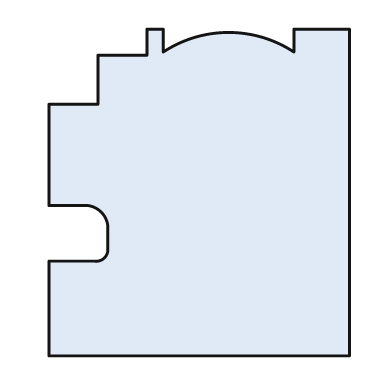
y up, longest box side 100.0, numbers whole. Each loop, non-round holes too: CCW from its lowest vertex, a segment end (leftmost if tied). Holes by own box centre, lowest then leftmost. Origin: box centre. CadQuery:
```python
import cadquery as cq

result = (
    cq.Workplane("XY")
    .moveTo(-46.0, -50.0)
    .lineTo(46.0, -50.0)
    .lineTo(46.0, 50.0)
    .lineTo(29.0, 50.0)
    .lineTo(29.0, 43.0)
    .threePointArc((9.0, 49.0), (-11.0, 43.0))
    .lineTo(-11.0, 50.0)
    .lineTo(-16.0, 50.0)
    .lineTo(-16.0, 42.0)
    .lineTo(-31.0, 42.0)
    .lineTo(-31.0, 27.0)
    .lineTo(-46.0, 27.0)
    .lineTo(-46.0, -4.0)
    .lineTo(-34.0, -4.0)
    .threePointArc((-30.0, -6.0), (-28.0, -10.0))
    .lineTo(-28.0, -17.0)
    .threePointArc((-29.0, -20.0), (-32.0, -21.0))
    .lineTo(-46.0, -21.0)
    .close()
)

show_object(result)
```